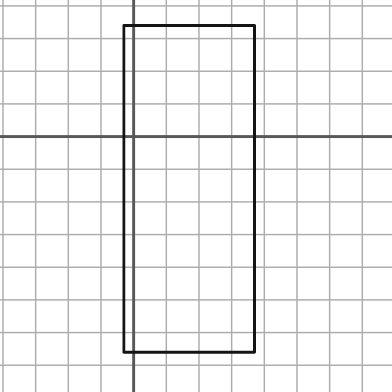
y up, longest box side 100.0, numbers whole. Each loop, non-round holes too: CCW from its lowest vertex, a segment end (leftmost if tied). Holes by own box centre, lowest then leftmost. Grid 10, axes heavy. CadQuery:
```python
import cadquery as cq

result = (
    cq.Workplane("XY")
    .moveTo(-3.0, -66.0)
    .lineTo(37.0, -66.0)
    .lineTo(37.0, 34.0)
    .lineTo(-3.0, 34.0)
    .close()
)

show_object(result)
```